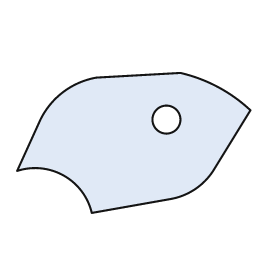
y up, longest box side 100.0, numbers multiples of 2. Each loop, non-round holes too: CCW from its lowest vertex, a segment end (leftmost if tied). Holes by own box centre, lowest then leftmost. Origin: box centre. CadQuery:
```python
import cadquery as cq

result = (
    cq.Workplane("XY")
    .moveTo(-18.0, -30.0)
    .lineTo(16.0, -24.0)
    .threePointArc((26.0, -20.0), (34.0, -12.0))
    .lineTo(50.0, 14.0)
    .threePointArc((36.0, 24.0), (20.0, 30.0))
    .lineTo(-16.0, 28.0)
    .threePointArc((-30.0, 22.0), (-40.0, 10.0))
    .lineTo(-50.0, -12.0)
    .threePointArc((-30.0, -14.0), (-18.0, -30.0))
    .close()
    .moveTo(14.0, 10.0)
    .circle(6.0)
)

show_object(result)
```